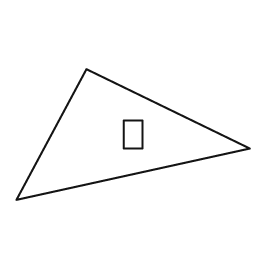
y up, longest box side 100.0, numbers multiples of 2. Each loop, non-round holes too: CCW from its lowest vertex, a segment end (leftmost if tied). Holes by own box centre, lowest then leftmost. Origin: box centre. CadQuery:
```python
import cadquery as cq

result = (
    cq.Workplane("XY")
    .moveTo(-50.0, -28.0)
    .lineTo(50.0, -6.0)
    .lineTo(-20.0, 28.0)
    .close()
    .moveTo(-4.0, -6.0)
    .lineTo(4.0, -6.0)
    .lineTo(4.0, 6.0)
    .lineTo(-4.0, 6.0)
    .close()
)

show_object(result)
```